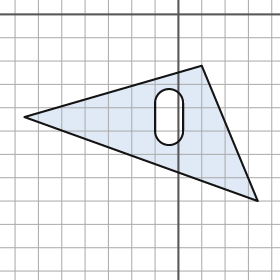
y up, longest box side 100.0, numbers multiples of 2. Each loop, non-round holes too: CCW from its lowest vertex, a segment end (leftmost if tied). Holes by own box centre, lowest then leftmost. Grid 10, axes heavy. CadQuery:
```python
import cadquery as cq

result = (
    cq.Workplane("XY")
    .moveTo(34.0, -80.0)
    .lineTo(10.0, -22.0)
    .lineTo(-66.0, -44.0)
    .close()
    .moveTo(-10.0, -50.0)
    .threePointArc((-4.0, -56.0), (2.0, -50.0))
    .lineTo(2.0, -38.0)
    .threePointArc((-4.0, -32.0), (-10.0, -38.0))
    .close()
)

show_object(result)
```